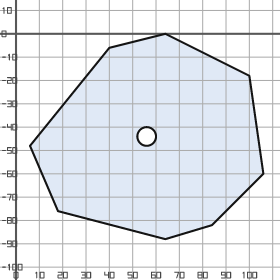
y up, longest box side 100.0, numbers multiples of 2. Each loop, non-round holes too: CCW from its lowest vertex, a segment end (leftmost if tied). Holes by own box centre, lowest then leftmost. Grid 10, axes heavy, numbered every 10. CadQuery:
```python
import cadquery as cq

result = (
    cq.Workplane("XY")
    .moveTo(64.0, -88.0)
    .lineTo(84.0, -82.0)
    .lineTo(106.0, -60.0)
    .lineTo(100.0, -18.0)
    .lineTo(64.0, 0.0)
    .lineTo(40.0, -6.0)
    .lineTo(6.0, -48.0)
    .lineTo(18.0, -76.0)
    .close()
    .moveTo(56.0, -44.0)
    .circle(4.0)
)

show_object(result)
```